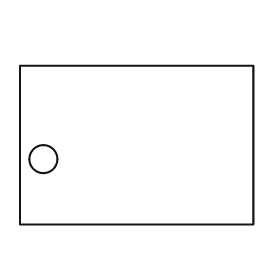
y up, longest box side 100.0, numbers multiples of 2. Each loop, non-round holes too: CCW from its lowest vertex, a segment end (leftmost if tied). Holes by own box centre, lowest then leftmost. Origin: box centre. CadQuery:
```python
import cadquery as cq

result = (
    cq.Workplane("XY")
    .moveTo(-50.0, -34.0)
    .lineTo(50.0, -34.0)
    .lineTo(50.0, 34.0)
    .lineTo(-50.0, 34.0)
    .close()
    .moveTo(-40.0, -6.0)
    .circle(6.0)
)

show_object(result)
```